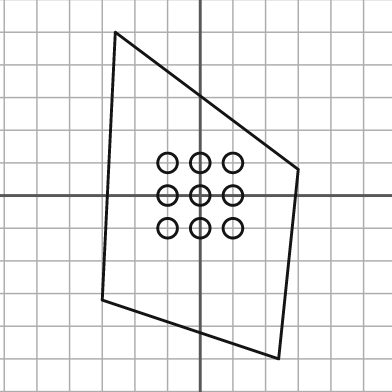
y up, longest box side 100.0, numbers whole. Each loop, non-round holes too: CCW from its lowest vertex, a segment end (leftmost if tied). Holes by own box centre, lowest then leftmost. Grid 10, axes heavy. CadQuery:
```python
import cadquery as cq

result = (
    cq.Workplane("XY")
    .moveTo(24.0, -50.0)
    .lineTo(30.0, 8.0)
    .lineTo(-26.0, 50.0)
    .lineTo(-30.0, -32.0)
    .close()
    .moveTo(-10.0, -10.0)
    .circle(3.0)
    .moveTo(0.0, -10.0)
    .circle(3.0)
    .moveTo(10.0, -10.0)
    .circle(3.0)
    .moveTo(-10.0, 0.0)
    .circle(3.0)
    .moveTo(0.0, 0.0)
    .circle(3.0)
    .moveTo(10.0, 0.0)
    .circle(3.0)
    .moveTo(-10.0, 10.0)
    .circle(3.0)
    .moveTo(0.0, 10.0)
    .circle(3.0)
    .moveTo(10.0, 10.0)
    .circle(3.0)
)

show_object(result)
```